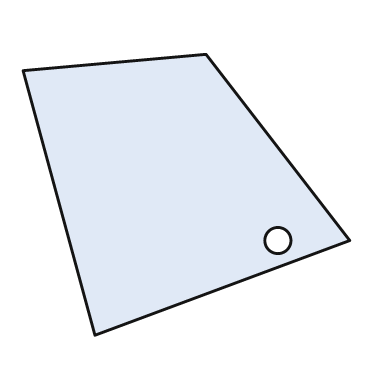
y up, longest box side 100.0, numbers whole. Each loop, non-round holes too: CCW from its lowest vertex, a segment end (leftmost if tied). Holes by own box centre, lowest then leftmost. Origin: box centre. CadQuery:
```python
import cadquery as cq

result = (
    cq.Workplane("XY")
    .moveTo(-28.0, -43.0)
    .lineTo(50.0, -14.0)
    .lineTo(6.0, 43.0)
    .lineTo(-50.0, 38.0)
    .close()
    .moveTo(28.0, -14.0)
    .circle(4.0)
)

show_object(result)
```